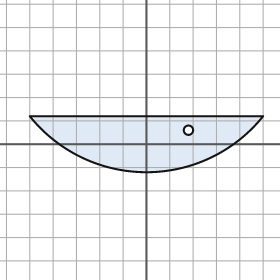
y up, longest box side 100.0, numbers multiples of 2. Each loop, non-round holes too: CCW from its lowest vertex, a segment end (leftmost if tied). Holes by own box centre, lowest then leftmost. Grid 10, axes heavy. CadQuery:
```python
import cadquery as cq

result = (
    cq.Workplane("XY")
    .moveTo(-50.0, 12.0)
    .threePointArc((0.0, -12.0), (50.0, 12.0))
    .close()
    .moveTo(18.0, 6.0)
    .circle(2.0)
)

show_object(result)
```